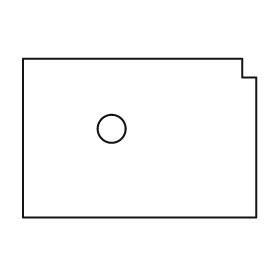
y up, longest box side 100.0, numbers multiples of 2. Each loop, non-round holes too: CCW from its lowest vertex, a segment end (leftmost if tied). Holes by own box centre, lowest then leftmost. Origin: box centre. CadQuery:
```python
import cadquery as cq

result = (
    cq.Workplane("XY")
    .moveTo(-50.0, -34.0)
    .lineTo(50.0, -34.0)
    .lineTo(50.0, 26.0)
    .lineTo(44.0, 26.0)
    .lineTo(44.0, 34.0)
    .lineTo(-50.0, 34.0)
    .close()
    .moveTo(-12.0, 4.0)
    .circle(6.0)
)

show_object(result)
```